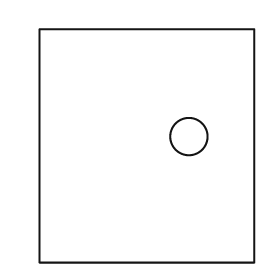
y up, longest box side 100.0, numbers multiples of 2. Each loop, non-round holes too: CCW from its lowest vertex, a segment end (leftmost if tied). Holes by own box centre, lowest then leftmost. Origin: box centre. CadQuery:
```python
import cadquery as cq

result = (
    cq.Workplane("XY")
    .moveTo(-46.0, -50.0)
    .lineTo(46.0, -50.0)
    .lineTo(46.0, 50.0)
    .lineTo(-46.0, 50.0)
    .close()
    .moveTo(18.0, 4.0)
    .circle(8.0)
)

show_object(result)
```